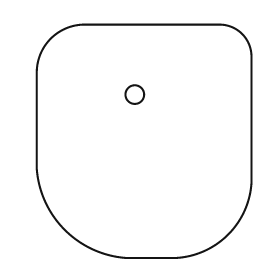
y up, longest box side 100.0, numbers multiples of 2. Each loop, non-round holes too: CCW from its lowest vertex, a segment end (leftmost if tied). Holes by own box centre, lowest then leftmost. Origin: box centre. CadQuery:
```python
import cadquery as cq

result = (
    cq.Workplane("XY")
    .moveTo(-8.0, -50.0)
    .lineTo(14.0, -50.0)
    .threePointArc((36.0, -40.0), (46.0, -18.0))
    .lineTo(46.0, 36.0)
    .threePointArc((42.0, 46.0), (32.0, 50.0))
    .lineTo(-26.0, 50.0)
    .threePointArc((-40.0, 44.0), (-46.0, 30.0))
    .lineTo(-46.0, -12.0)
    .threePointArc((-34.0, -38.0), (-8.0, -50.0))
    .close()
    .moveTo(-4.0, 20.0)
    .circle(4.0)
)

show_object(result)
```